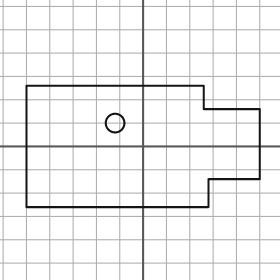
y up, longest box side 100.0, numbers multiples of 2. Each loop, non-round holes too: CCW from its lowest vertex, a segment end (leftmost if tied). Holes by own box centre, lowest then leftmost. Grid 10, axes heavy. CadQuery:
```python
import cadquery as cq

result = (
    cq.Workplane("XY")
    .moveTo(-50.0, -26.0)
    .lineTo(28.0, -26.0)
    .lineTo(28.0, -14.0)
    .lineTo(50.0, -14.0)
    .lineTo(50.0, 16.0)
    .lineTo(26.0, 16.0)
    .lineTo(26.0, 26.0)
    .lineTo(-50.0, 26.0)
    .close()
    .moveTo(-12.0, 10.0)
    .circle(4.0)
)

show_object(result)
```